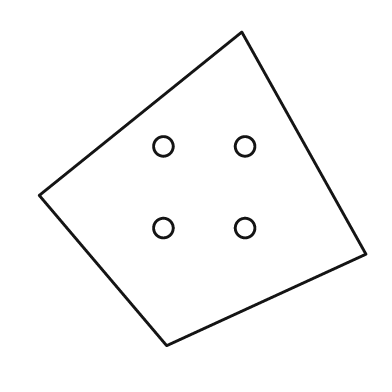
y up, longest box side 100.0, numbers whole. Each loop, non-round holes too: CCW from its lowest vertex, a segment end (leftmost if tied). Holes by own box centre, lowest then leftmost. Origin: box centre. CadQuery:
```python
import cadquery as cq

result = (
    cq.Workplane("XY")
    .moveTo(-11.0, -48.0)
    .lineTo(50.0, -20.0)
    .lineTo(12.0, 48.0)
    .lineTo(-50.0, -2.0)
    .close()
    .moveTo(-12.0, -12.0)
    .circle(3.0)
    .moveTo(13.0, -12.0)
    .circle(3.0)
    .moveTo(-12.0, 13.0)
    .circle(3.0)
    .moveTo(13.0, 13.0)
    .circle(3.0)
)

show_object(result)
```